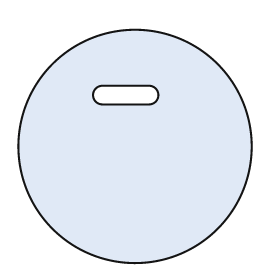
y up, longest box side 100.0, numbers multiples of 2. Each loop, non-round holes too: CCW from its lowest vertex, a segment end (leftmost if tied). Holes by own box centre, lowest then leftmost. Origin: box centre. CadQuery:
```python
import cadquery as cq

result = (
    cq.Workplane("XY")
    .moveTo(0.0, 0.0)
    .circle(50.0)
    .moveTo(-14.0, 18.0)
    .lineTo(6.0, 18.0)
    .threePointArc((10.0, 22.0), (6.0, 26.0))
    .lineTo(-14.0, 26.0)
    .threePointArc((-18.0, 22.0), (-14.0, 18.0))
    .close()
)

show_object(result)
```